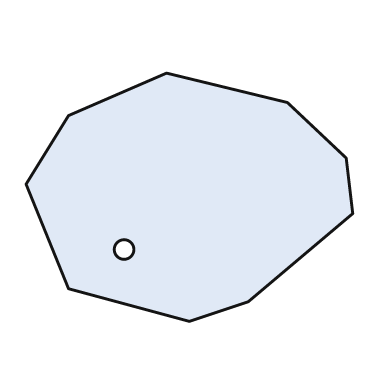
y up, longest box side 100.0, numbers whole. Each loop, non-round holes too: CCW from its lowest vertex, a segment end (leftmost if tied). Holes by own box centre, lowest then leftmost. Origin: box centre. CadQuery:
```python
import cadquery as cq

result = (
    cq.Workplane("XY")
    .moveTo(0.0, -38.0)
    .lineTo(18.0, -32.0)
    .lineTo(50.0, -5.0)
    .lineTo(48.0, 12.0)
    .lineTo(30.0, 29.0)
    .lineTo(-7.0, 38.0)
    .lineTo(-37.0, 25.0)
    .lineTo(-50.0, 4.0)
    .lineTo(-37.0, -28.0)
    .close()
    .moveTo(-20.0, -16.0)
    .circle(3.0)
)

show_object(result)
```